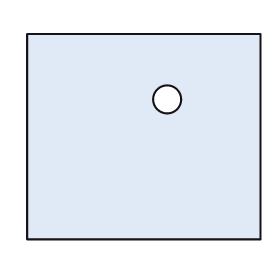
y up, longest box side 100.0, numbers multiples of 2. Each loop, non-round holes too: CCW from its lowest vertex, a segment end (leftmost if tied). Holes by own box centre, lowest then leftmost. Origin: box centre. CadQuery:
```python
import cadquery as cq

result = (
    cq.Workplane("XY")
    .moveTo(-50.0, -44.0)
    .lineTo(50.0, -44.0)
    .lineTo(50.0, 44.0)
    .lineTo(-50.0, 44.0)
    .close()
    .moveTo(10.0, 16.0)
    .circle(6.0)
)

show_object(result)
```